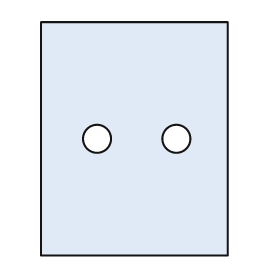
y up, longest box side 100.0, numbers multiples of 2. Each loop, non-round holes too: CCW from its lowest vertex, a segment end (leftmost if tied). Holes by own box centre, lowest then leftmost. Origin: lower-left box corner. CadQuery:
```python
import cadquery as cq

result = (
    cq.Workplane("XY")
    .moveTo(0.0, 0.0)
    .lineTo(80.0, 0.0)
    .lineTo(80.0, 100.0)
    .lineTo(0.0, 100.0)
    .close()
    .moveTo(24.0, 50.0)
    .circle(6.0)
    .moveTo(58.0, 50.0)
    .circle(6.0)
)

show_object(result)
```